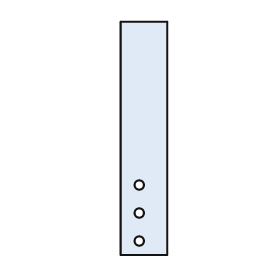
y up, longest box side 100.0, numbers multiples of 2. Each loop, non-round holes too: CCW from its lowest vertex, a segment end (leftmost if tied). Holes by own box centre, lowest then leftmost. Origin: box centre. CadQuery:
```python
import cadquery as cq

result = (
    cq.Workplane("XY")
    .moveTo(-10.0, -50.0)
    .lineTo(10.0, -50.0)
    .lineTo(10.0, 50.0)
    .lineTo(-10.0, 50.0)
    .close()
    .moveTo(-2.0, -44.0)
    .circle(2.0)
    .moveTo(-2.0, -32.0)
    .circle(2.0)
    .moveTo(-2.0, -20.0)
    .circle(2.0)
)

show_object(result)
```